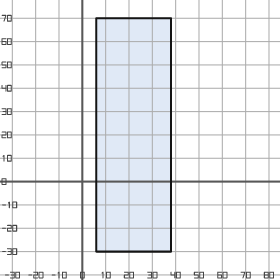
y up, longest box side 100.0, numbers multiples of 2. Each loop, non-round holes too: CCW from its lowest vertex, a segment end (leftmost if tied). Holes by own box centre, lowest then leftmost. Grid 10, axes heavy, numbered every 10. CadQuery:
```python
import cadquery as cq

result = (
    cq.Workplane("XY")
    .moveTo(6.0, -30.0)
    .lineTo(38.0, -30.0)
    .lineTo(38.0, 70.0)
    .lineTo(6.0, 70.0)
    .close()
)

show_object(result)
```